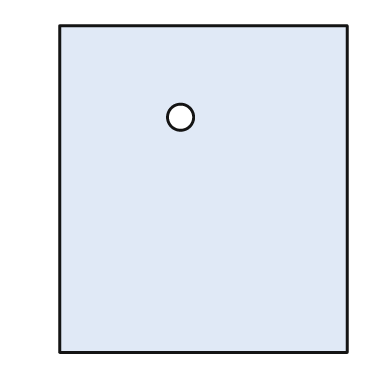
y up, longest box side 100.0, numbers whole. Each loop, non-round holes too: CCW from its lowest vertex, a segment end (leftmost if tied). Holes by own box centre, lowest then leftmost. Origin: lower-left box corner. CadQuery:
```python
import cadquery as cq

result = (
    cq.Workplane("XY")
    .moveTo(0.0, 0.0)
    .lineTo(88.0, 0.0)
    .lineTo(88.0, 100.0)
    .lineTo(0.0, 100.0)
    .close()
    .moveTo(37.0, 72.0)
    .circle(4.0)
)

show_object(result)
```